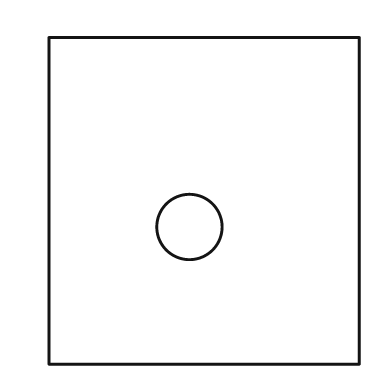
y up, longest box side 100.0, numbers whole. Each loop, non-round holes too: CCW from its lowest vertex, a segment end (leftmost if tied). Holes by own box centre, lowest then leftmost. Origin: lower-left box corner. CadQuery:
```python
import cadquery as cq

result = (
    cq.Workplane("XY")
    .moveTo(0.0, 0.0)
    .lineTo(95.0, 0.0)
    .lineTo(95.0, 100.0)
    .lineTo(0.0, 100.0)
    .close()
    .moveTo(43.0, 42.0)
    .circle(10.0)
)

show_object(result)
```